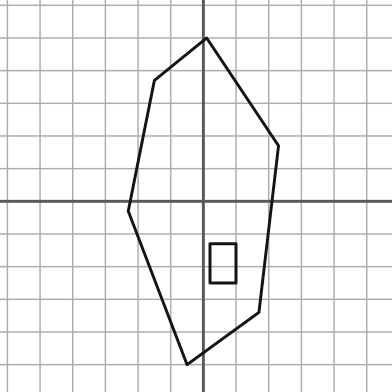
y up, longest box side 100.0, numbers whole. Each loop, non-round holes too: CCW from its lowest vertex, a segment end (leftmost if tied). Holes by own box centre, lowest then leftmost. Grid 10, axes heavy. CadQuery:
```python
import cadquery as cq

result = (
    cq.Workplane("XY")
    .moveTo(-5.0, -50.0)
    .lineTo(17.0, -34.0)
    .lineTo(23.0, 17.0)
    .lineTo(1.0, 50.0)
    .lineTo(-15.0, 37.0)
    .lineTo(-23.0, -3.0)
    .close()
    .moveTo(2.0, -25.0)
    .lineTo(10.0, -25.0)
    .lineTo(10.0, -13.0)
    .lineTo(2.0, -13.0)
    .close()
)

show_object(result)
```